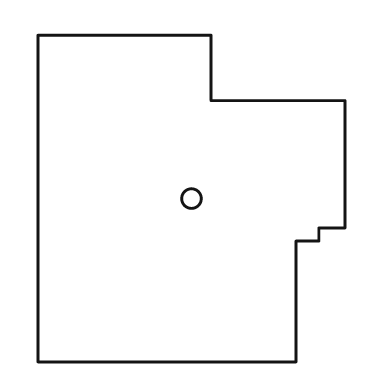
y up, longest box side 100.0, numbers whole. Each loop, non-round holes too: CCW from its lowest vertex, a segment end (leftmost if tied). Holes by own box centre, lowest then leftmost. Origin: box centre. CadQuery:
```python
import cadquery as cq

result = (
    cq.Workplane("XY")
    .moveTo(-47.0, -50.0)
    .lineTo(32.0, -50.0)
    .lineTo(32.0, -13.0)
    .lineTo(39.0, -13.0)
    .lineTo(39.0, -9.0)
    .lineTo(47.0, -9.0)
    .lineTo(47.0, 30.0)
    .lineTo(6.0, 30.0)
    .lineTo(6.0, 50.0)
    .lineTo(-47.0, 50.0)
    .close()
    .moveTo(0.0, 0.0)
    .circle(3.0)
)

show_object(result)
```